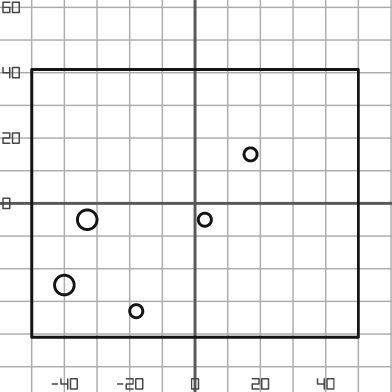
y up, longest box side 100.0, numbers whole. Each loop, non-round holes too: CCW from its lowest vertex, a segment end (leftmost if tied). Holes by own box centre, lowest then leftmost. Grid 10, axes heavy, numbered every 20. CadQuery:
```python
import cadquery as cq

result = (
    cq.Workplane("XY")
    .moveTo(-50.0, -41.0)
    .lineTo(50.0, -41.0)
    .lineTo(50.0, 41.0)
    .lineTo(-50.0, 41.0)
    .close()
    .moveTo(-18.0, -33.0)
    .circle(2.0)
    .moveTo(-40.0, -25.0)
    .circle(3.0)
    .moveTo(-33.0, -5.0)
    .circle(3.0)
    .moveTo(3.0, -5.0)
    .circle(2.0)
    .moveTo(17.0, 15.0)
    .circle(2.0)
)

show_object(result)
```